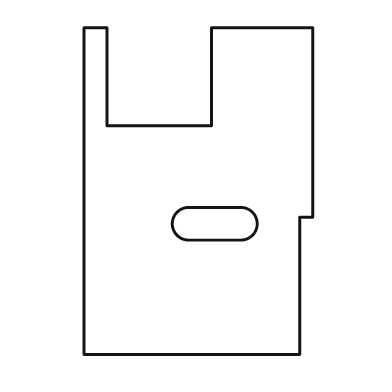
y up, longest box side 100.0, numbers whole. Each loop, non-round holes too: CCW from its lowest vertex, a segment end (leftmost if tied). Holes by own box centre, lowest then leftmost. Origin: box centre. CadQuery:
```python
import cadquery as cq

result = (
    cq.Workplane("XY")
    .moveTo(-35.0, -50.0)
    .lineTo(31.0, -50.0)
    .lineTo(31.0, -8.0)
    .lineTo(35.0, -8.0)
    .lineTo(35.0, 50.0)
    .lineTo(4.0, 50.0)
    .lineTo(4.0, 20.0)
    .lineTo(-28.0, 20.0)
    .lineTo(-28.0, 50.0)
    .lineTo(-35.0, 50.0)
    .close()
    .moveTo(-3.0, -15.0)
    .lineTo(13.0, -15.0)
    .threePointArc((18.0, -10.0), (13.0, -5.0))
    .lineTo(-3.0, -5.0)
    .threePointArc((-8.0, -10.0), (-3.0, -15.0))
    .close()
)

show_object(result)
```